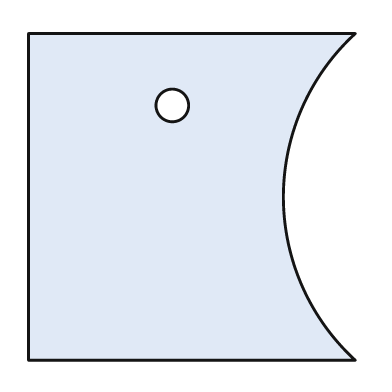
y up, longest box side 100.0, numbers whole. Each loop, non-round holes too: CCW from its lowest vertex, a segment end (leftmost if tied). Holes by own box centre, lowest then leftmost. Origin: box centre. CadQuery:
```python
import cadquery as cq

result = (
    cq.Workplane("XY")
    .moveTo(-50.0, -50.0)
    .lineTo(50.0, -50.0)
    .threePointArc((28.0, 0.0), (50.0, 50.0))
    .lineTo(-50.0, 50.0)
    .close()
    .moveTo(-6.0, 28.0)
    .circle(5.0)
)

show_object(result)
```